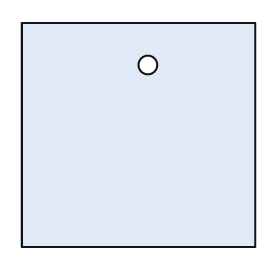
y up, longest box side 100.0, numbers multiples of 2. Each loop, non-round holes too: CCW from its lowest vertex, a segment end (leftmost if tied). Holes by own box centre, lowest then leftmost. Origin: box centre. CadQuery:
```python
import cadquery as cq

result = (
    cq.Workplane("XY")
    .moveTo(-50.0, -48.0)
    .lineTo(50.0, -48.0)
    .lineTo(50.0, 48.0)
    .lineTo(-50.0, 48.0)
    .close()
    .moveTo(4.0, 30.0)
    .circle(4.0)
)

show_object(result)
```